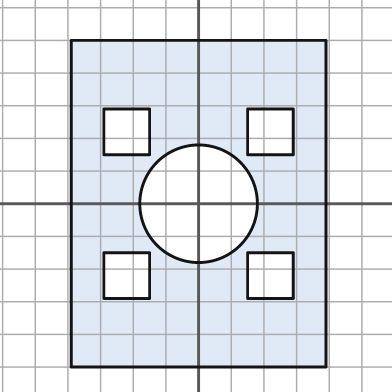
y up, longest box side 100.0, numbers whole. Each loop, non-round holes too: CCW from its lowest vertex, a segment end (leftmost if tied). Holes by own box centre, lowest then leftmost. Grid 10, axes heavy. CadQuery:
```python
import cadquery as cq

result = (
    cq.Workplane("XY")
    .moveTo(-39.0, -50.0)
    .lineTo(39.0, -50.0)
    .lineTo(39.0, 50.0)
    .lineTo(-39.0, 50.0)
    .close()
    .moveTo(-29.0, -29.0)
    .lineTo(-15.0, -29.0)
    .lineTo(-15.0, -15.0)
    .lineTo(-29.0, -15.0)
    .close()
    .moveTo(15.0, -29.0)
    .lineTo(29.0, -29.0)
    .lineTo(29.0, -15.0)
    .lineTo(15.0, -15.0)
    .close()
    .moveTo(0.0, 0.0)
    .circle(18.0)
    .moveTo(-29.0, 15.0)
    .lineTo(-15.0, 15.0)
    .lineTo(-15.0, 29.0)
    .lineTo(-29.0, 29.0)
    .close()
    .moveTo(15.0, 15.0)
    .lineTo(29.0, 15.0)
    .lineTo(29.0, 29.0)
    .lineTo(15.0, 29.0)
    .close()
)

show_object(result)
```